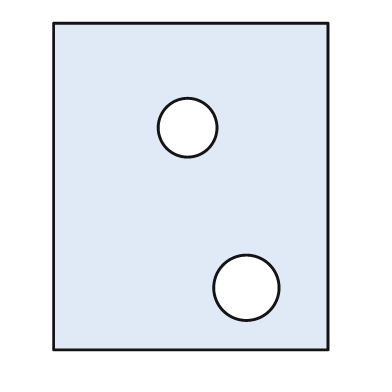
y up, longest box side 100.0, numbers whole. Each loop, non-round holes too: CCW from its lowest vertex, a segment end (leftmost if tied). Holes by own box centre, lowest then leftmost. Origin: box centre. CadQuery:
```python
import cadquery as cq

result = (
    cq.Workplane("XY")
    .moveTo(-42.0, -50.0)
    .lineTo(42.0, -50.0)
    .lineTo(42.0, 50.0)
    .lineTo(-42.0, 50.0)
    .close()
    .moveTo(17.0, -31.0)
    .circle(10.0)
    .moveTo(-1.0, 18.0)
    .circle(9.0)
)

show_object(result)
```